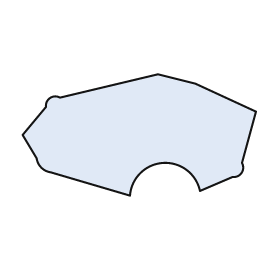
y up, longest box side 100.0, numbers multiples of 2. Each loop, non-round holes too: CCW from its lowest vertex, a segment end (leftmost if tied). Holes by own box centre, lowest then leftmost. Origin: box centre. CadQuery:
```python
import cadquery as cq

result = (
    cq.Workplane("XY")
    .moveTo(-4.0, -26.0)
    .threePointArc((10.0, -12.0), (26.0, -24.0))
    .lineTo(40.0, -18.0)
    .threePointArc((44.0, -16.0), (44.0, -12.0))
    .lineTo(50.0, 10.0)
    .lineTo(24.0, 22.0)
    .lineTo(8.0, 26.0)
    .lineTo(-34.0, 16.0)
    .threePointArc((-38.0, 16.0), (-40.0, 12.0))
    .lineTo(-50.0, 0.0)
    .lineTo(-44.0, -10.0)
    .threePointArc((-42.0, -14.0), (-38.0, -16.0))
    .close()
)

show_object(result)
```